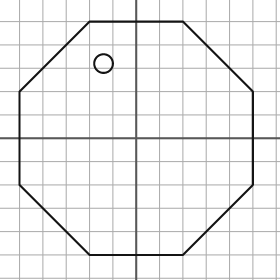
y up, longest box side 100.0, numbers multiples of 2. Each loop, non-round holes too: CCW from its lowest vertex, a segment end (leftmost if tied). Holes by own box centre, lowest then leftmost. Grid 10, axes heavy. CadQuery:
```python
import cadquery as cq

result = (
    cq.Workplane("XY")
    .moveTo(-20.0, -50.0)
    .lineTo(20.0, -50.0)
    .lineTo(50.0, -20.0)
    .lineTo(50.0, 20.0)
    .lineTo(20.0, 50.0)
    .lineTo(-20.0, 50.0)
    .lineTo(-50.0, 20.0)
    .lineTo(-50.0, -20.0)
    .close()
    .moveTo(-14.0, 32.0)
    .circle(4.0)
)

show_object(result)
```